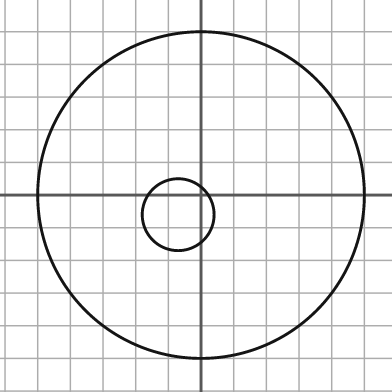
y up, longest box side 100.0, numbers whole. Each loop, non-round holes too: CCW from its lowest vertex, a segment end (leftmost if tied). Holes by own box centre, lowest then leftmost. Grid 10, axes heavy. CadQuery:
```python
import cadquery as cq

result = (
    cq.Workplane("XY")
    .moveTo(0.0, 0.0)
    .circle(50.0)
    .moveTo(-7.0, -6.0)
    .circle(11.0)
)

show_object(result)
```